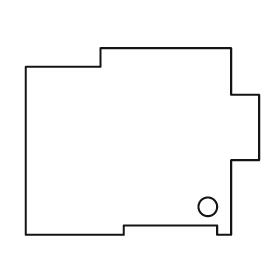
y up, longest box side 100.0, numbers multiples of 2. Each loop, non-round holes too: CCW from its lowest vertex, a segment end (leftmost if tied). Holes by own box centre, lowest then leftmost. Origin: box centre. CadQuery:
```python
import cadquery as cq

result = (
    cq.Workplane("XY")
    .moveTo(-50.0, -40.0)
    .lineTo(-8.0, -40.0)
    .lineTo(-8.0, -36.0)
    .lineTo(32.0, -36.0)
    .lineTo(32.0, -40.0)
    .lineTo(38.0, -40.0)
    .lineTo(38.0, -8.0)
    .lineTo(50.0, -8.0)
    .lineTo(50.0, 20.0)
    .lineTo(38.0, 20.0)
    .lineTo(38.0, 40.0)
    .lineTo(-18.0, 40.0)
    .lineTo(-18.0, 32.0)
    .lineTo(-50.0, 32.0)
    .close()
    .moveTo(28.0, -28.0)
    .circle(4.0)
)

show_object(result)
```